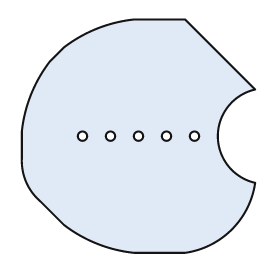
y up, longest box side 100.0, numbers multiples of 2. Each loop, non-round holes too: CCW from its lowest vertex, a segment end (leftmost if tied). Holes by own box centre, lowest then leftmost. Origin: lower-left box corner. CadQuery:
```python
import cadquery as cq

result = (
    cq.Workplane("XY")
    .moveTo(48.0, 0.0)
    .lineTo(70.0, 0.0)
    .threePointArc((90.0, 10.0), (100.0, 30.0))
    .threePointArc((84.0, 50.0), (100.0, 70.0))
    .lineTo(70.0, 100.0)
    .lineTo(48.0, 100.0)
    .threePointArc((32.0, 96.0), (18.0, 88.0))
    .lineTo(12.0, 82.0)
    .threePointArc((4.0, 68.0), (0.0, 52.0))
    .lineTo(0.0, 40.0)
    .threePointArc((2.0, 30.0), (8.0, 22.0))
    .lineTo(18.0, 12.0)
    .threePointArc((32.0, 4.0), (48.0, 0.0))
    .close()
    .moveTo(26.0, 50.0)
    .circle(2.0)
    .moveTo(38.0, 50.0)
    .circle(2.0)
    .moveTo(50.0, 50.0)
    .circle(2.0)
    .moveTo(62.0, 50.0)
    .circle(2.0)
    .moveTo(74.0, 50.0)
    .circle(2.0)
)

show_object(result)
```